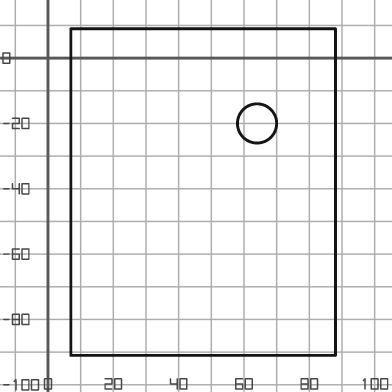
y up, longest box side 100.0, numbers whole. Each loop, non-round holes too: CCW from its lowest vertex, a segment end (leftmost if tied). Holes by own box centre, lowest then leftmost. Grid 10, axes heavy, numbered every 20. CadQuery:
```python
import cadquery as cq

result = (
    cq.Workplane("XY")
    .moveTo(7.0, -91.0)
    .lineTo(88.0, -91.0)
    .lineTo(88.0, 9.0)
    .lineTo(7.0, 9.0)
    .close()
    .moveTo(64.0, -20.0)
    .circle(6.0)
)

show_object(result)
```